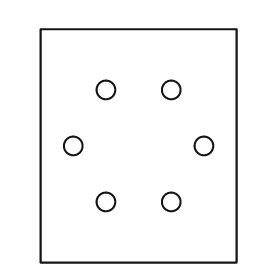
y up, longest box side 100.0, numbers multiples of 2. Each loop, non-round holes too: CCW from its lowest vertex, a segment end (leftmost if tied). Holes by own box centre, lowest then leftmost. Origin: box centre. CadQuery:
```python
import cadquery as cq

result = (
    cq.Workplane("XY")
    .moveTo(-42.0, -50.0)
    .lineTo(42.0, -50.0)
    .lineTo(42.0, 50.0)
    .lineTo(-42.0, 50.0)
    .close()
    .moveTo(-14.0, -24.0)
    .circle(4.0)
    .moveTo(14.0, -24.0)
    .circle(4.0)
    .moveTo(-28.0, 0.0)
    .circle(4.0)
    .moveTo(28.0, 0.0)
    .circle(4.0)
    .moveTo(-14.0, 24.0)
    .circle(4.0)
    .moveTo(14.0, 24.0)
    .circle(4.0)
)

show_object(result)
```